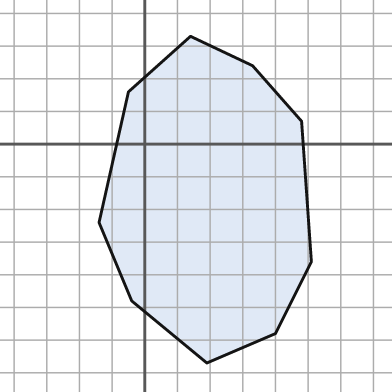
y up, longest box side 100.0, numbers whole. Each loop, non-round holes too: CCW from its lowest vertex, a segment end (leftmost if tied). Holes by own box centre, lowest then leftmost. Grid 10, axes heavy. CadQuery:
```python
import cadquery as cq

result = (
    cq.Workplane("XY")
    .moveTo(19.0, -67.0)
    .lineTo(40.0, -58.0)
    .lineTo(51.0, -36.0)
    .lineTo(48.0, 7.0)
    .lineTo(33.0, 24.0)
    .lineTo(14.0, 33.0)
    .lineTo(-5.0, 16.0)
    .lineTo(-14.0, -24.0)
    .lineTo(-4.0, -48.0)
    .close()
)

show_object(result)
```